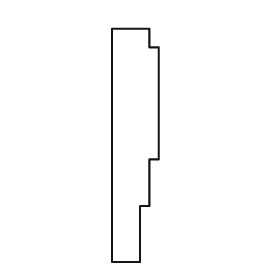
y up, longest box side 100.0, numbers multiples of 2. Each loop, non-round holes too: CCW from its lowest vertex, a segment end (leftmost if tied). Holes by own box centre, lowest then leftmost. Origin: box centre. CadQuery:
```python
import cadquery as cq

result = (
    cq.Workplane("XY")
    .moveTo(-10.0, -50.0)
    .lineTo(2.0, -50.0)
    .lineTo(2.0, -26.0)
    .lineTo(6.0, -26.0)
    .lineTo(6.0, -6.0)
    .lineTo(10.0, -6.0)
    .lineTo(10.0, 42.0)
    .lineTo(6.0, 42.0)
    .lineTo(6.0, 50.0)
    .lineTo(-10.0, 50.0)
    .close()
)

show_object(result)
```